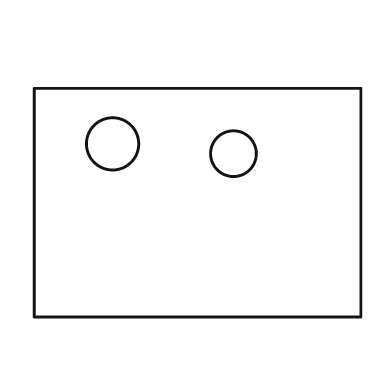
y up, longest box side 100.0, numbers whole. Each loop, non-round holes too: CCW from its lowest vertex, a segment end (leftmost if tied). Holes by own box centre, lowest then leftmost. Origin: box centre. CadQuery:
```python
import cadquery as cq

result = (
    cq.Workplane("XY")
    .moveTo(-50.0, -35.0)
    .lineTo(50.0, -35.0)
    .lineTo(50.0, 35.0)
    .lineTo(-50.0, 35.0)
    .close()
    .moveTo(11.0, 15.0)
    .circle(7.0)
    .moveTo(-26.0, 18.0)
    .circle(8.0)
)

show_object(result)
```